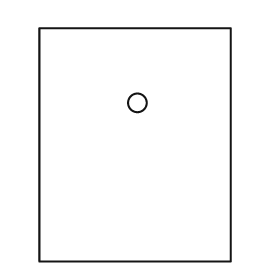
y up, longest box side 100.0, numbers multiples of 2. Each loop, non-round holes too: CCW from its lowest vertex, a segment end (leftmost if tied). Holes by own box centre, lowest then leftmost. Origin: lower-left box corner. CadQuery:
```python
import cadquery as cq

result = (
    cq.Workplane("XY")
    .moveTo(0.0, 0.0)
    .lineTo(82.0, 0.0)
    .lineTo(82.0, 100.0)
    .lineTo(0.0, 100.0)
    .close()
    .moveTo(42.0, 68.0)
    .circle(4.0)
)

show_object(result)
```